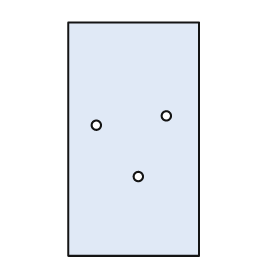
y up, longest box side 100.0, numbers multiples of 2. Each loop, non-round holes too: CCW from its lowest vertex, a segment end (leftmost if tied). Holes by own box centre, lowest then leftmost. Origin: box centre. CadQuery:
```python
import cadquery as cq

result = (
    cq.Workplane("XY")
    .moveTo(-28.0, -50.0)
    .lineTo(28.0, -50.0)
    .lineTo(28.0, 50.0)
    .lineTo(-28.0, 50.0)
    .close()
    .moveTo(2.0, -16.0)
    .circle(2.0)
    .moveTo(-16.0, 6.0)
    .circle(2.0)
    .moveTo(14.0, 10.0)
    .circle(2.0)
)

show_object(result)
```